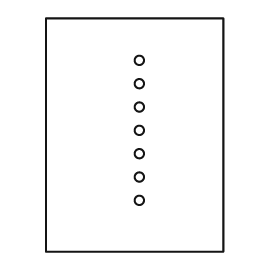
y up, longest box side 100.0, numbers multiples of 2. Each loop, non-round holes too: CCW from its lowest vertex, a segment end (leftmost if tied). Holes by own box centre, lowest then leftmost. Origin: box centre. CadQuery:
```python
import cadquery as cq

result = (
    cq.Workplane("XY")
    .moveTo(-38.0, -50.0)
    .lineTo(38.0, -50.0)
    .lineTo(38.0, 50.0)
    .lineTo(-38.0, 50.0)
    .close()
    .moveTo(2.0, -28.0)
    .circle(2.0)
    .moveTo(2.0, -18.0)
    .circle(2.0)
    .moveTo(2.0, -8.0)
    .circle(2.0)
    .moveTo(2.0, 2.0)
    .circle(2.0)
    .moveTo(2.0, 12.0)
    .circle(2.0)
    .moveTo(2.0, 22.0)
    .circle(2.0)
    .moveTo(2.0, 32.0)
    .circle(2.0)
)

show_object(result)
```